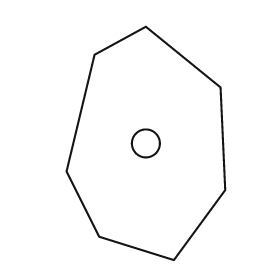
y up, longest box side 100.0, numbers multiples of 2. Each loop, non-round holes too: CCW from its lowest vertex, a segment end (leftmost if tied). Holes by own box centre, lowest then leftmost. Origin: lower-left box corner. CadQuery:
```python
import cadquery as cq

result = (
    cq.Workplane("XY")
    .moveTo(46.0, 0.0)
    .lineTo(68.0, 30.0)
    .lineTo(66.0, 74.0)
    .lineTo(34.0, 100.0)
    .lineTo(12.0, 88.0)
    .lineTo(0.0, 38.0)
    .lineTo(14.0, 10.0)
    .close()
    .moveTo(34.0, 50.0)
    .circle(6.0)
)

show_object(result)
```